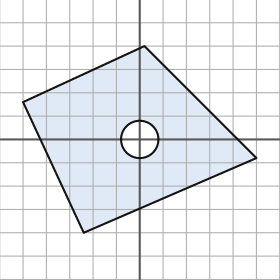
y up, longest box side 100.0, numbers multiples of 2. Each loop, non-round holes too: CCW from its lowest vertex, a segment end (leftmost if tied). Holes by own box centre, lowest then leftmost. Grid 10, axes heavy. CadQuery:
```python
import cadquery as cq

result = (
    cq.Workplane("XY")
    .moveTo(-24.0, -40.0)
    .lineTo(50.0, -8.0)
    .lineTo(2.0, 40.0)
    .lineTo(-50.0, 16.0)
    .close()
    .moveTo(0.0, 0.0)
    .circle(8.0)
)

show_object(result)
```